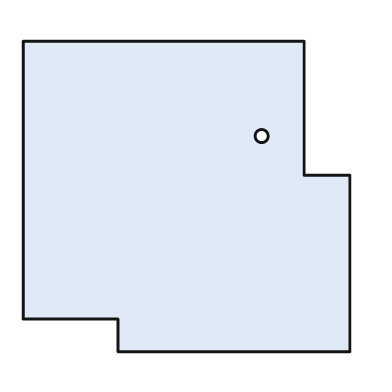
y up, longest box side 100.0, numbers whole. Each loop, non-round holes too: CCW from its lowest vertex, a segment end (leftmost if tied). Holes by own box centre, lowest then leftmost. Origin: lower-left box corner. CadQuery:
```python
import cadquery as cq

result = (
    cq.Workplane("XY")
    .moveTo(29.0, 0.0)
    .lineTo(100.0, 0.0)
    .lineTo(100.0, 54.0)
    .lineTo(86.0, 54.0)
    .lineTo(86.0, 95.0)
    .lineTo(0.0, 95.0)
    .lineTo(0.0, 10.0)
    .lineTo(29.0, 10.0)
    .close()
    .moveTo(73.0, 66.0)
    .circle(2.0)
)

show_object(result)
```